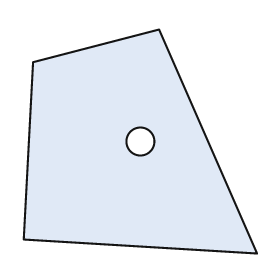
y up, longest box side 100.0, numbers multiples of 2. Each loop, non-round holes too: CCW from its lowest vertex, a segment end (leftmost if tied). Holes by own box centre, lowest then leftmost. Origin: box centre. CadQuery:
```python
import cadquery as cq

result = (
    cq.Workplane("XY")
    .moveTo(50.0, -48.0)
    .lineTo(8.0, 48.0)
    .lineTo(-46.0, 34.0)
    .lineTo(-50.0, -42.0)
    .close()
    .moveTo(0.0, 0.0)
    .circle(6.0)
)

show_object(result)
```